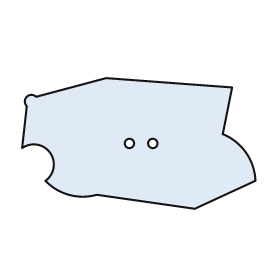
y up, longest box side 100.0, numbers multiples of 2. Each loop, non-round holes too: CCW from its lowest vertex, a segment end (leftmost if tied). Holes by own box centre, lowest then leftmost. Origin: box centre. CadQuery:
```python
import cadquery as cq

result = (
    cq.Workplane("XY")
    .moveTo(24.0, -28.0)
    .lineTo(50.0, -16.0)
    .threePointArc((46.0, -4.0), (36.0, 4.0))
    .lineTo(40.0, 24.0)
    .lineTo(-14.0, 28.0)
    .lineTo(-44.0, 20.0)
    .threePointArc((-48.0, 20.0), (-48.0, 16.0))
    .lineTo(-50.0, -2.0)
    .threePointArc((-38.0, -4.0), (-40.0, -16.0))
    .threePointArc((-30.0, -22.0), (-18.0, -22.0))
    .close()
    .moveTo(-4.0, 0.0)
    .circle(2.0)
    .moveTo(6.0, 0.0)
    .circle(2.0)
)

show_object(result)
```